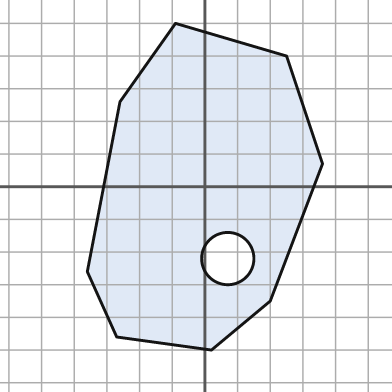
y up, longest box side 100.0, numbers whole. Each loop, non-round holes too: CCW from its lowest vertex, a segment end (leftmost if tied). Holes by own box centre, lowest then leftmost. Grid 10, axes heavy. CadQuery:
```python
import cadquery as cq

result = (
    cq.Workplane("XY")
    .moveTo(2.0, -50.0)
    .lineTo(20.0, -35.0)
    .lineTo(36.0, 7.0)
    .lineTo(25.0, 40.0)
    .lineTo(-9.0, 50.0)
    .lineTo(-26.0, 26.0)
    .lineTo(-36.0, -26.0)
    .lineTo(-27.0, -46.0)
    .close()
    .moveTo(7.0, -22.0)
    .circle(8.0)
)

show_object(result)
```